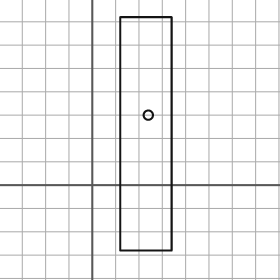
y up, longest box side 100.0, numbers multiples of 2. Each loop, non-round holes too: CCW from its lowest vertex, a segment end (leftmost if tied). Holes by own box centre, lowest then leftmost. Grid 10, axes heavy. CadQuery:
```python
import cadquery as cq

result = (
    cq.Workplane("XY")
    .moveTo(12.0, -28.0)
    .lineTo(34.0, -28.0)
    .lineTo(34.0, 72.0)
    .lineTo(12.0, 72.0)
    .close()
    .moveTo(24.0, 30.0)
    .circle(2.0)
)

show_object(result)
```